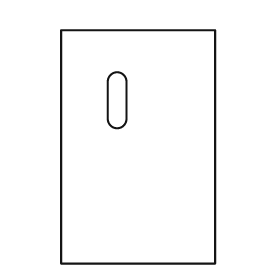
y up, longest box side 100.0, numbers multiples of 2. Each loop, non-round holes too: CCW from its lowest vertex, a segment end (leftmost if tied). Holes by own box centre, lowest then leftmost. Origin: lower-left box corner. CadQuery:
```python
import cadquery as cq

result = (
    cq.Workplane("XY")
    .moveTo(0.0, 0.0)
    .lineTo(66.0, 0.0)
    .lineTo(66.0, 100.0)
    .lineTo(0.0, 100.0)
    .close()
    .moveTo(20.0, 62.0)
    .threePointArc((24.0, 58.0), (28.0, 62.0))
    .lineTo(28.0, 78.0)
    .threePointArc((24.0, 82.0), (20.0, 78.0))
    .close()
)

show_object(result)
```